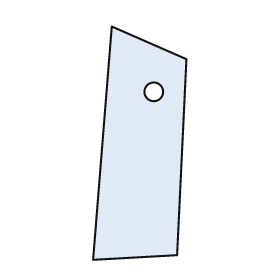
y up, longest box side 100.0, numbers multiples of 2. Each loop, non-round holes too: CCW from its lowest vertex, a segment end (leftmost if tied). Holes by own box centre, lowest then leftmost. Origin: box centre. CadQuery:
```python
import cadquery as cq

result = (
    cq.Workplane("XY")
    .moveTo(-20.0, -50.0)
    .lineTo(16.0, -48.0)
    .lineTo(20.0, 36.0)
    .lineTo(-12.0, 50.0)
    .close()
    .moveTo(6.0, 22.0)
    .circle(4.0)
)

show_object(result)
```